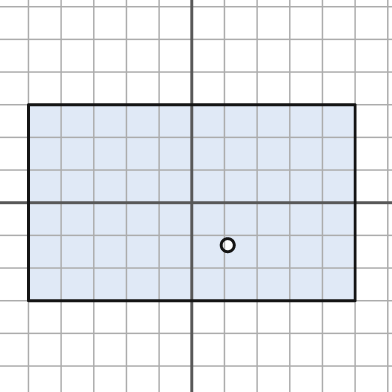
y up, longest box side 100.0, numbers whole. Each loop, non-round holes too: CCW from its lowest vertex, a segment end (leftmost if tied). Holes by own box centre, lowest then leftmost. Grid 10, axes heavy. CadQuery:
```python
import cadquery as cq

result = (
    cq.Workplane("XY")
    .moveTo(-50.0, -30.0)
    .lineTo(50.0, -30.0)
    .lineTo(50.0, 30.0)
    .lineTo(-50.0, 30.0)
    .close()
    .moveTo(11.0, -13.0)
    .circle(2.0)
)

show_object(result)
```